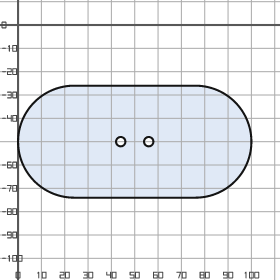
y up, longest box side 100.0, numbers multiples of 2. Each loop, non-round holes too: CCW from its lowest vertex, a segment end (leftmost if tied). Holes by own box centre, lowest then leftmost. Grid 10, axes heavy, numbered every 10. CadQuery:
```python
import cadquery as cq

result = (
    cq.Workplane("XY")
    .moveTo(24.0, -74.0)
    .lineTo(76.0, -74.0)
    .threePointArc((100.0, -50.0), (76.0, -26.0))
    .lineTo(24.0, -26.0)
    .threePointArc((0.0, -50.0), (24.0, -74.0))
    .close()
    .moveTo(44.0, -50.0)
    .circle(2.0)
    .moveTo(56.0, -50.0)
    .circle(2.0)
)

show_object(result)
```